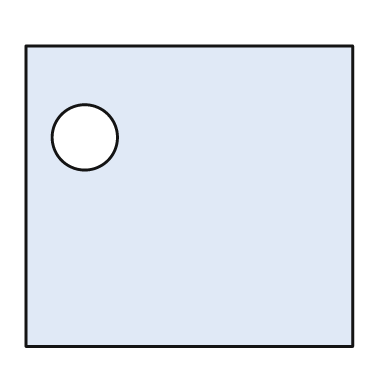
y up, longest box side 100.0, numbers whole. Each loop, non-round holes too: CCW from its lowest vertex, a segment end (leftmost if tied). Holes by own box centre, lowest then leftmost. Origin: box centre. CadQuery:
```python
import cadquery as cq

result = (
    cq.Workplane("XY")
    .moveTo(-50.0, -46.0)
    .lineTo(50.0, -46.0)
    .lineTo(50.0, 46.0)
    .lineTo(-50.0, 46.0)
    .close()
    .moveTo(-32.0, 18.0)
    .circle(10.0)
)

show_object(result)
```